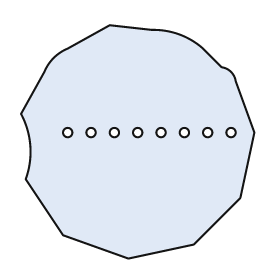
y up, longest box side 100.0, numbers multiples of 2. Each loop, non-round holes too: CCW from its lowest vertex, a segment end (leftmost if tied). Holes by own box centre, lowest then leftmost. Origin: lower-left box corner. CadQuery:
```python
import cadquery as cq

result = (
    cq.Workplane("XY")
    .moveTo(46.0, 0.0)
    .lineTo(74.0, 6.0)
    .lineTo(94.0, 26.0)
    .lineTo(100.0, 54.0)
    .lineTo(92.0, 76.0)
    .threePointArc((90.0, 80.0), (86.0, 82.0))
    .lineTo(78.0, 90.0)
    .threePointArc((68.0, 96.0), (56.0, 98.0))
    .lineTo(38.0, 100.0)
    .lineTo(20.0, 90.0)
    .threePointArc((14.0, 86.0), (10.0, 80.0))
    .lineTo(0.0, 62.0)
    .threePointArc((4.0, 48.0), (2.0, 34.0))
    .lineTo(18.0, 10.0)
    .close()
    .moveTo(20.0, 54.0)
    .circle(2.0)
    .moveTo(30.0, 54.0)
    .circle(2.0)
    .moveTo(40.0, 54.0)
    .circle(2.0)
    .moveTo(50.0, 54.0)
    .circle(2.0)
    .moveTo(60.0, 54.0)
    .circle(2.0)
    .moveTo(70.0, 54.0)
    .circle(2.0)
    .moveTo(80.0, 54.0)
    .circle(2.0)
    .moveTo(90.0, 54.0)
    .circle(2.0)
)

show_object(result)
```